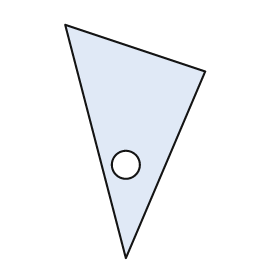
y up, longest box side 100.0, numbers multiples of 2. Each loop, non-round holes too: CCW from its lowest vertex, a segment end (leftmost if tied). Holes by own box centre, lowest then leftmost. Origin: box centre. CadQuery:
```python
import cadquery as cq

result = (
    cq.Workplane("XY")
    .moveTo(-4.0, -50.0)
    .lineTo(30.0, 30.0)
    .lineTo(-30.0, 50.0)
    .close()
    .moveTo(-4.0, -10.0)
    .circle(6.0)
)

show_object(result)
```